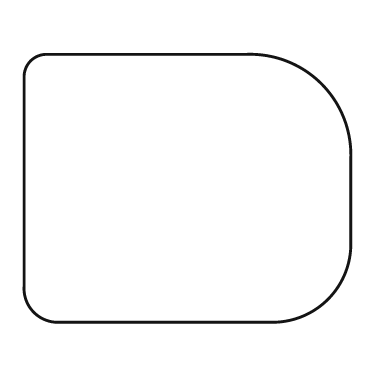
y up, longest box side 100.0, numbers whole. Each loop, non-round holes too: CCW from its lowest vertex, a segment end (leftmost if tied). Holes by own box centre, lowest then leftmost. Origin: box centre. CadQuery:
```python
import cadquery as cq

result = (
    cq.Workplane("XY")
    .moveTo(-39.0, -41.0)
    .lineTo(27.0, -41.0)
    .threePointArc((43.0, -34.0), (50.0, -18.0))
    .lineTo(50.0, 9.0)
    .threePointArc((41.0, 32.0), (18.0, 41.0))
    .lineTo(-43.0, 41.0)
    .threePointArc((-48.0, 39.0), (-50.0, 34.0))
    .lineTo(-50.0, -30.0)
    .threePointArc((-47.0, -38.0), (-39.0, -41.0))
    .close()
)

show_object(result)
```